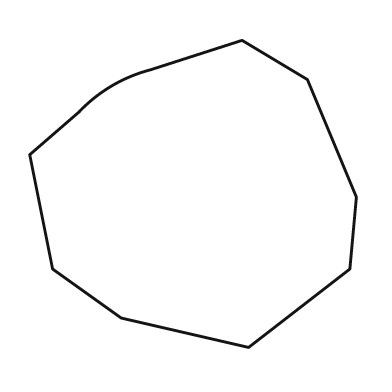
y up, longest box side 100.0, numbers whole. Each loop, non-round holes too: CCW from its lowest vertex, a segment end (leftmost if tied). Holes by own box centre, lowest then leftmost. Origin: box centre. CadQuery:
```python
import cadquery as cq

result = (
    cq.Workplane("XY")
    .moveTo(17.0, -47.0)
    .lineTo(48.0, -23.0)
    .lineTo(50.0, -1.0)
    .lineTo(35.0, 35.0)
    .lineTo(15.0, 47.0)
    .lineTo(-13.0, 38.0)
    .threePointArc((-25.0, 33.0), (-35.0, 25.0))
    .lineTo(-50.0, 12.0)
    .lineTo(-43.0, -23.0)
    .lineTo(-22.0, -38.0)
    .close()
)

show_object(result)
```